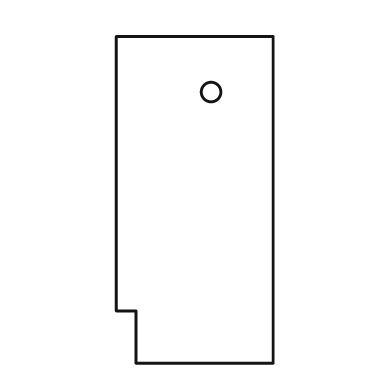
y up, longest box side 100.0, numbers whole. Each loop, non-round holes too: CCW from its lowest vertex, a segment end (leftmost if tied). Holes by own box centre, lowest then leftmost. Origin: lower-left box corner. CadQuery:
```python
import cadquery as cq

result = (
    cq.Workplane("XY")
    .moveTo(6.0, 0.0)
    .lineTo(48.0, 0.0)
    .lineTo(48.0, 100.0)
    .lineTo(0.0, 100.0)
    .lineTo(0.0, 16.0)
    .lineTo(6.0, 16.0)
    .close()
    .moveTo(29.0, 83.0)
    .circle(3.0)
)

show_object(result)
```